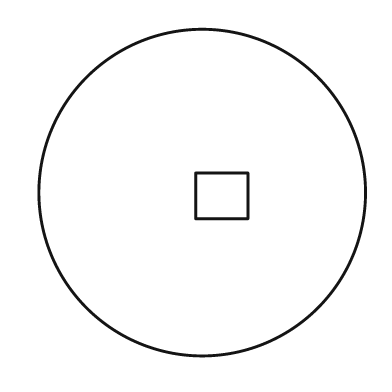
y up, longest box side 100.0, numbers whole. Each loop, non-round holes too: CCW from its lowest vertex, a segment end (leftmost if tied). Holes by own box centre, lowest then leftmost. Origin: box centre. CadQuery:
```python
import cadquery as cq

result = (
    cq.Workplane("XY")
    .moveTo(0.0, 0.0)
    .circle(50.0)
    .moveTo(-2.0, -8.0)
    .lineTo(14.0, -8.0)
    .lineTo(14.0, 6.0)
    .lineTo(-2.0, 6.0)
    .close()
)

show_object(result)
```